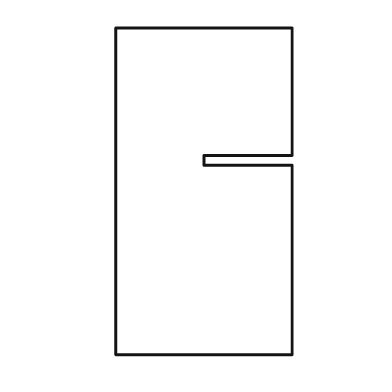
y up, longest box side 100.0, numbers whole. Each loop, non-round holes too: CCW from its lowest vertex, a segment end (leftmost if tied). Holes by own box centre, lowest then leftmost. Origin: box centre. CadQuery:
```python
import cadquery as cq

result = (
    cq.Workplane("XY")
    .moveTo(-27.0, -50.0)
    .lineTo(27.0, -50.0)
    .lineTo(27.0, 8.0)
    .lineTo(0.0, 8.0)
    .lineTo(0.0, 11.0)
    .lineTo(27.0, 11.0)
    .lineTo(27.0, 50.0)
    .lineTo(-27.0, 50.0)
    .close()
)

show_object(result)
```